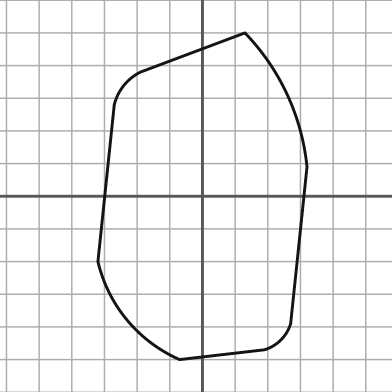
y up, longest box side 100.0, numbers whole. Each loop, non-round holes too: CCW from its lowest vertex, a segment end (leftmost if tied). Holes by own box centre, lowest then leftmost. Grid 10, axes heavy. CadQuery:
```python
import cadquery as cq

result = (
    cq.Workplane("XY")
    .moveTo(-7.0, -50.0)
    .lineTo(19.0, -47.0)
    .threePointArc((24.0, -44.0), (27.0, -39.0))
    .lineTo(32.0, 9.0)
    .threePointArc((26.0, 31.0), (13.0, 50.0))
    .lineTo(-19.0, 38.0)
    .threePointArc((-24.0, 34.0), (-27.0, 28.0))
    .lineTo(-32.0, -20.0)
    .threePointArc((-23.0, -38.0), (-7.0, -50.0))
    .close()
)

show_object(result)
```